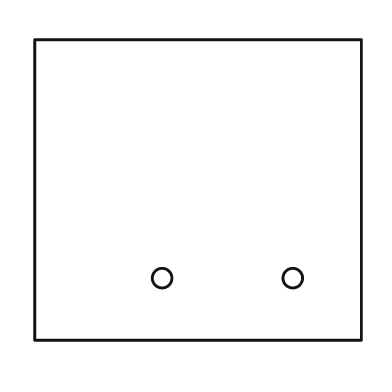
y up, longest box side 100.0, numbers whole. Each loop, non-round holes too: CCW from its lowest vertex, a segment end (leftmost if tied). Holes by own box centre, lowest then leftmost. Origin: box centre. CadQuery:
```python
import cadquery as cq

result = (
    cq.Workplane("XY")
    .moveTo(-50.0, -46.0)
    .lineTo(50.0, -46.0)
    .lineTo(50.0, 46.0)
    .lineTo(-50.0, 46.0)
    .close()
    .moveTo(-11.0, -27.0)
    .circle(3.0)
    .moveTo(29.0, -27.0)
    .circle(3.0)
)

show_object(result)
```